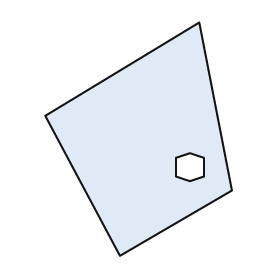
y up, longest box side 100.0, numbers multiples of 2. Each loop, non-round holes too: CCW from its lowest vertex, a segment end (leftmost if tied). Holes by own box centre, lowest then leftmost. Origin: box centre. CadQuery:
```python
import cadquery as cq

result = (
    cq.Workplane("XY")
    .moveTo(-8.0, -50.0)
    .lineTo(40.0, -22.0)
    .lineTo(26.0, 50.0)
    .lineTo(-40.0, 10.0)
    .close()
    .moveTo(22.0, -18.0)
    .lineTo(28.0, -16.0)
    .lineTo(28.0, -8.0)
    .lineTo(22.0, -6.0)
    .lineTo(16.0, -8.0)
    .lineTo(16.0, -16.0)
    .close()
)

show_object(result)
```